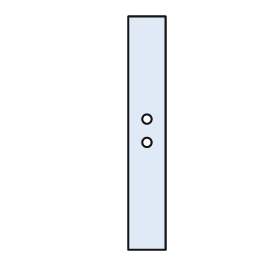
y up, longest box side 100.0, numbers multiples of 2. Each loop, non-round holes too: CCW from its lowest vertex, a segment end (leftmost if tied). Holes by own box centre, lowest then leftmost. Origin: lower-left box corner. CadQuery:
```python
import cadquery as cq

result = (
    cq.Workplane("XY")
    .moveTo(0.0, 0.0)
    .lineTo(16.0, 0.0)
    .lineTo(16.0, 100.0)
    .lineTo(0.0, 100.0)
    .close()
    .moveTo(8.0, 46.0)
    .circle(2.0)
    .moveTo(8.0, 56.0)
    .circle(2.0)
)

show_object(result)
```